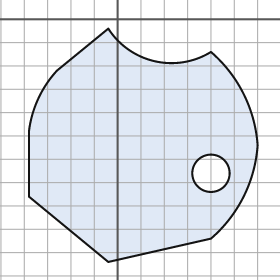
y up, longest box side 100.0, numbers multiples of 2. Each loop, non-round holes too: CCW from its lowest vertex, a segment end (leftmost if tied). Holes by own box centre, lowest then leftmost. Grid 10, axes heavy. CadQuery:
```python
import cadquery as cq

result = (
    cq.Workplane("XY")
    .moveTo(-4.0, -104.0)
    .lineTo(40.0, -94.0)
    .threePointArc((54.0, -76.0), (60.0, -54.0))
    .threePointArc((54.0, -32.0), (40.0, -14.0))
    .threePointArc((16.0, -18.0), (-4.0, -4.0))
    .lineTo(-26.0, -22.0)
    .threePointArc((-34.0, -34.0), (-38.0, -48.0))
    .lineTo(-38.0, -76.0)
    .close()
    .moveTo(40.0, -66.0)
    .circle(8.0)
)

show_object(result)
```